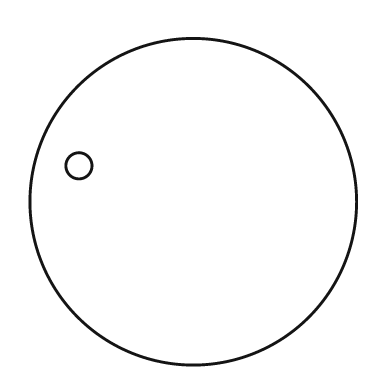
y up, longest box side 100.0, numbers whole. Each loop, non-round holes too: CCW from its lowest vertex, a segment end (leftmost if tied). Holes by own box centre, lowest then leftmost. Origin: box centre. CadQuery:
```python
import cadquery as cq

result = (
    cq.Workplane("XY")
    .moveTo(0.0, 0.0)
    .circle(50.0)
    .moveTo(-35.0, 11.0)
    .circle(4.0)
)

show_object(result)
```